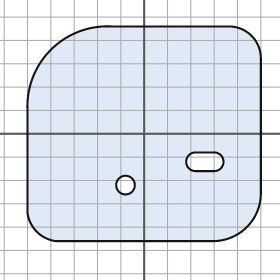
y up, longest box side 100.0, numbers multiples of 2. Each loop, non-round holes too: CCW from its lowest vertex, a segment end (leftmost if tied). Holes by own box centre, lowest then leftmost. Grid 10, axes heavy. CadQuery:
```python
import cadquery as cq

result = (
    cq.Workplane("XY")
    .moveTo(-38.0, -46.0)
    .lineTo(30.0, -46.0)
    .threePointArc((44.0, -40.0), (50.0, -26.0))
    .lineTo(50.0, 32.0)
    .threePointArc((46.0, 42.0), (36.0, 46.0))
    .lineTo(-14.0, 46.0)
    .threePointArc((-40.0, 36.0), (-50.0, 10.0))
    .lineTo(-50.0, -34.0)
    .threePointArc((-46.0, -42.0), (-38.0, -46.0))
    .close()
    .moveTo(-8.0, -22.0)
    .circle(4.0)
    .moveTo(22.0, -16.0)
    .lineTo(30.0, -16.0)
    .threePointArc((34.0, -12.0), (30.0, -8.0))
    .lineTo(22.0, -8.0)
    .threePointArc((18.0, -12.0), (22.0, -16.0))
    .close()
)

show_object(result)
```